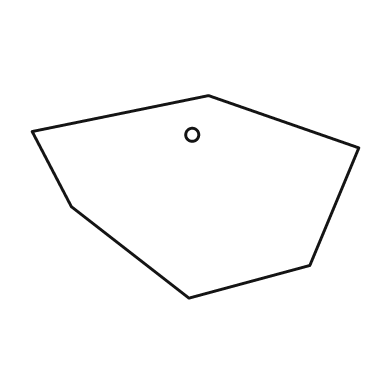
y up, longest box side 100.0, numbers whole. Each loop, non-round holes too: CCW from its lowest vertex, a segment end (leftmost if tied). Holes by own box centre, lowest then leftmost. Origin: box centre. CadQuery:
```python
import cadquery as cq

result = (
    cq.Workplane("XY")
    .moveTo(-2.0, -31.0)
    .lineTo(35.0, -21.0)
    .lineTo(50.0, 15.0)
    .lineTo(4.0, 31.0)
    .lineTo(-50.0, 20.0)
    .lineTo(-38.0, -3.0)
    .close()
    .moveTo(-1.0, 19.0)
    .circle(2.0)
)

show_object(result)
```